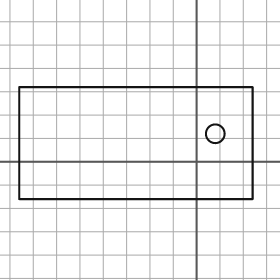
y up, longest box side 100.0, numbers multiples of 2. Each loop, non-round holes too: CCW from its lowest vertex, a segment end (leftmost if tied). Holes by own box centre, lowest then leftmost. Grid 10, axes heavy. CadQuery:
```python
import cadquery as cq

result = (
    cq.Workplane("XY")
    .moveTo(-76.0, -16.0)
    .lineTo(24.0, -16.0)
    .lineTo(24.0, 32.0)
    .lineTo(-76.0, 32.0)
    .close()
    .moveTo(8.0, 12.0)
    .circle(4.0)
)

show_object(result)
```